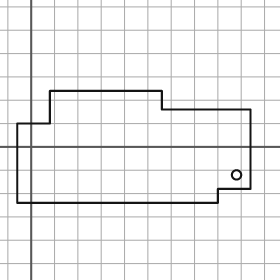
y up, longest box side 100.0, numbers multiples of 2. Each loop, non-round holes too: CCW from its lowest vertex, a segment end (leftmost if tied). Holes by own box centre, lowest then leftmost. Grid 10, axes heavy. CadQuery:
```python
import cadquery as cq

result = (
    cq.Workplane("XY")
    .moveTo(-6.0, -24.0)
    .lineTo(80.0, -24.0)
    .lineTo(80.0, -18.0)
    .lineTo(94.0, -18.0)
    .lineTo(94.0, 16.0)
    .lineTo(56.0, 16.0)
    .lineTo(56.0, 24.0)
    .lineTo(8.0, 24.0)
    .lineTo(8.0, 10.0)
    .lineTo(-6.0, 10.0)
    .close()
    .moveTo(88.0, -12.0)
    .circle(2.0)
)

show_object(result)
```